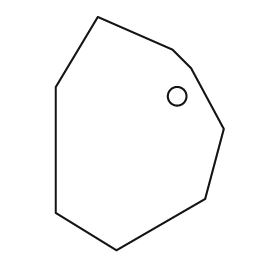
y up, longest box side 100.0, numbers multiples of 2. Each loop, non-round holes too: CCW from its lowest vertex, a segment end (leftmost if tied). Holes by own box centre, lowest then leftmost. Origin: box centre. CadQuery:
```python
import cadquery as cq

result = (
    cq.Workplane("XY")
    .moveTo(-10.0, -50.0)
    .lineTo(28.0, -28.0)
    .lineTo(36.0, 2.0)
    .lineTo(22.0, 28.0)
    .lineTo(14.0, 36.0)
    .lineTo(-18.0, 50.0)
    .lineTo(-36.0, 20.0)
    .lineTo(-36.0, -34.0)
    .close()
    .moveTo(16.0, 16.0)
    .circle(4.0)
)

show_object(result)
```